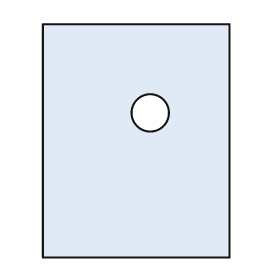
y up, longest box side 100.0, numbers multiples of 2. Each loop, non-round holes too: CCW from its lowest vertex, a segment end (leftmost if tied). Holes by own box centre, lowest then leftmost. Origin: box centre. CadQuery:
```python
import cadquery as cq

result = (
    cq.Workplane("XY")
    .moveTo(-40.0, -50.0)
    .lineTo(40.0, -50.0)
    .lineTo(40.0, 50.0)
    .lineTo(-40.0, 50.0)
    .close()
    .moveTo(6.0, 12.0)
    .circle(8.0)
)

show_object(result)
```